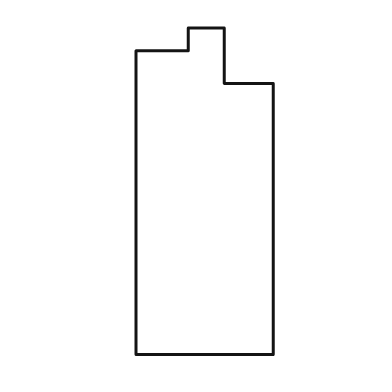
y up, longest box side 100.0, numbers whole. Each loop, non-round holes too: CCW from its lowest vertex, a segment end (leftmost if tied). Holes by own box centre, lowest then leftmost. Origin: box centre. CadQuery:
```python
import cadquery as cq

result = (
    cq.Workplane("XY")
    .moveTo(-21.0, -50.0)
    .lineTo(21.0, -50.0)
    .lineTo(21.0, 33.0)
    .lineTo(6.0, 33.0)
    .lineTo(6.0, 50.0)
    .lineTo(-5.0, 50.0)
    .lineTo(-5.0, 43.0)
    .lineTo(-21.0, 43.0)
    .close()
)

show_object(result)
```